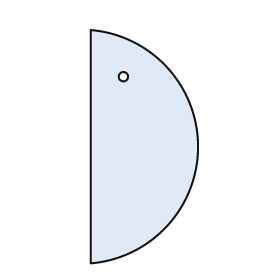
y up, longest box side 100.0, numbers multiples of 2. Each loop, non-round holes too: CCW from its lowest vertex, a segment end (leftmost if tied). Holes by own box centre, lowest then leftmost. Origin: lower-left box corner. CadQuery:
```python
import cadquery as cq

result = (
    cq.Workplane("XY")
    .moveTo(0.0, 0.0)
    .threePointArc((46.0, 50.0), (0.0, 100.0))
    .close()
    .moveTo(14.0, 80.0)
    .circle(2.0)
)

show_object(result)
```